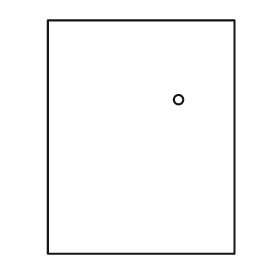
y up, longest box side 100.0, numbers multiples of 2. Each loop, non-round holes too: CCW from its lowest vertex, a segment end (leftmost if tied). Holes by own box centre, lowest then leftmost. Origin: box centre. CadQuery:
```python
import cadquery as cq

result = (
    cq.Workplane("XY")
    .moveTo(-40.0, -50.0)
    .lineTo(40.0, -50.0)
    .lineTo(40.0, 50.0)
    .lineTo(-40.0, 50.0)
    .close()
    .moveTo(16.0, 16.0)
    .circle(2.0)
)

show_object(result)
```